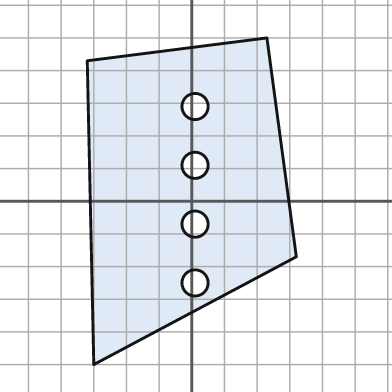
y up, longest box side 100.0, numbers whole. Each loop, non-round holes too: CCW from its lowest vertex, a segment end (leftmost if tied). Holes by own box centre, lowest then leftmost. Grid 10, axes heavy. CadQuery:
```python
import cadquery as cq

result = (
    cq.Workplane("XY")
    .moveTo(-30.0, -50.0)
    .lineTo(32.0, -17.0)
    .lineTo(23.0, 50.0)
    .lineTo(-32.0, 43.0)
    .close()
    .moveTo(1.0, -25.0)
    .circle(4.0)
    .moveTo(1.0, -7.0)
    .circle(4.0)
    .moveTo(1.0, 11.0)
    .circle(4.0)
    .moveTo(1.0, 29.0)
    .circle(4.0)
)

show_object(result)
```